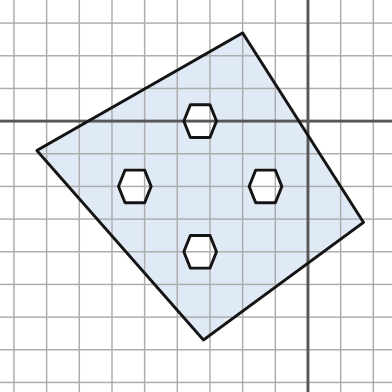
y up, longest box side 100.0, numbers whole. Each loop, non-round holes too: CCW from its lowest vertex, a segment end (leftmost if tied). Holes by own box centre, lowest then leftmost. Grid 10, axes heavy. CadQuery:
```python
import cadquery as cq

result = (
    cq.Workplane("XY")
    .moveTo(-32.0, -67.0)
    .lineTo(17.0, -31.0)
    .lineTo(-20.0, 27.0)
    .lineTo(-83.0, -9.0)
    .close()
    .moveTo(-36.0, -45.0)
    .lineTo(-30.0, -45.0)
    .lineTo(-28.0, -40.0)
    .lineTo(-30.0, -35.0)
    .lineTo(-36.0, -35.0)
    .lineTo(-38.0, -40.0)
    .close()
    .moveTo(-56.0, -25.0)
    .lineTo(-50.0, -25.0)
    .lineTo(-48.0, -20.0)
    .lineTo(-50.0, -15.0)
    .lineTo(-56.0, -15.0)
    .lineTo(-58.0, -20.0)
    .close()
    .moveTo(-16.0, -25.0)
    .lineTo(-10.0, -25.0)
    .lineTo(-8.0, -20.0)
    .lineTo(-10.0, -15.0)
    .lineTo(-16.0, -15.0)
    .lineTo(-18.0, -20.0)
    .close()
    .moveTo(-36.0, -5.0)
    .lineTo(-30.0, -5.0)
    .lineTo(-28.0, 0.0)
    .lineTo(-30.0, 5.0)
    .lineTo(-36.0, 5.0)
    .lineTo(-38.0, 0.0)
    .close()
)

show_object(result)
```